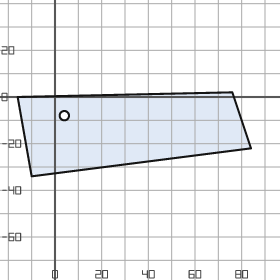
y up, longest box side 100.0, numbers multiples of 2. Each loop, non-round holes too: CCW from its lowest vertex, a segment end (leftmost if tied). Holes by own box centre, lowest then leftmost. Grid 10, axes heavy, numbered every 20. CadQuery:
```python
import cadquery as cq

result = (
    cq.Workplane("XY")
    .moveTo(-10.0, -34.0)
    .lineTo(84.0, -22.0)
    .lineTo(76.0, 2.0)
    .lineTo(-16.0, 0.0)
    .close()
    .moveTo(4.0, -8.0)
    .circle(2.0)
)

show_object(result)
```